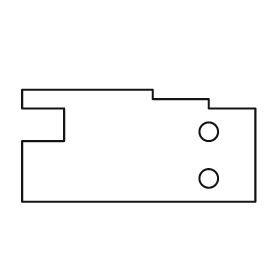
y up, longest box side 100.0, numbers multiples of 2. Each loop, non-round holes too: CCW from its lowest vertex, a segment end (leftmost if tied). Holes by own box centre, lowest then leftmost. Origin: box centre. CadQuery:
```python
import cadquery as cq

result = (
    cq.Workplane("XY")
    .moveTo(-50.0, -24.0)
    .lineTo(50.0, -24.0)
    .lineTo(50.0, 16.0)
    .lineTo(30.0, 16.0)
    .lineTo(30.0, 20.0)
    .lineTo(6.0, 20.0)
    .lineTo(6.0, 24.0)
    .lineTo(-50.0, 24.0)
    .lineTo(-50.0, 16.0)
    .lineTo(-32.0, 16.0)
    .lineTo(-32.0, 2.0)
    .lineTo(-50.0, 2.0)
    .close()
    .moveTo(30.0, -14.0)
    .circle(4.0)
    .moveTo(30.0, 6.0)
    .circle(4.0)
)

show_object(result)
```